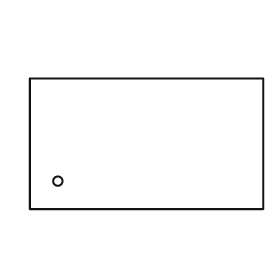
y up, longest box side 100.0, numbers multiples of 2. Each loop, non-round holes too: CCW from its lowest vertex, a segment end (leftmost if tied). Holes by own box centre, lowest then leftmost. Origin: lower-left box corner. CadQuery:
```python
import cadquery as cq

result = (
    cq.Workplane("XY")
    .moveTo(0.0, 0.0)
    .lineTo(100.0, 0.0)
    .lineTo(100.0, 56.0)
    .lineTo(0.0, 56.0)
    .close()
    .moveTo(12.0, 12.0)
    .circle(2.0)
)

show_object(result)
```